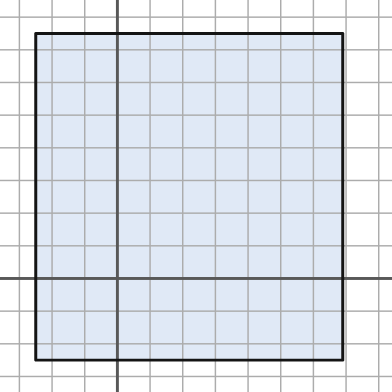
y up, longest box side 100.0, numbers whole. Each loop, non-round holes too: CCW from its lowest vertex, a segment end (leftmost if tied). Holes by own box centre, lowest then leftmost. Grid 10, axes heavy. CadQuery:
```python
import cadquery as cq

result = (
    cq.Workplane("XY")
    .moveTo(-25.0, -25.0)
    .lineTo(69.0, -25.0)
    .lineTo(69.0, 75.0)
    .lineTo(-25.0, 75.0)
    .close()
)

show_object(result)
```